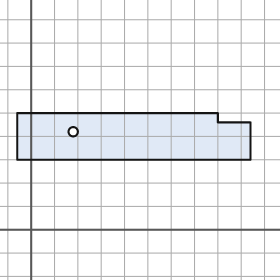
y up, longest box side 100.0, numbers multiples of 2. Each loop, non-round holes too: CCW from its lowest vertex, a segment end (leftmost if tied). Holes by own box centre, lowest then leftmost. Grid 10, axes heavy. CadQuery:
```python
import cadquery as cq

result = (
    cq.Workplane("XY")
    .moveTo(-6.0, 30.0)
    .lineTo(94.0, 30.0)
    .lineTo(94.0, 46.0)
    .lineTo(80.0, 46.0)
    .lineTo(80.0, 50.0)
    .lineTo(-6.0, 50.0)
    .close()
    .moveTo(18.0, 42.0)
    .circle(2.0)
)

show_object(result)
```